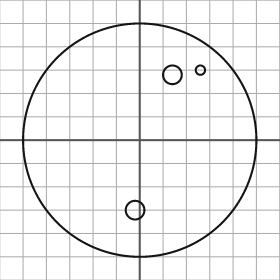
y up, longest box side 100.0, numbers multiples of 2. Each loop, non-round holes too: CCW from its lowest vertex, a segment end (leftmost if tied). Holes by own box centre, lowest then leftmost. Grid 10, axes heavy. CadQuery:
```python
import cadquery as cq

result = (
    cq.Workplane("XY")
    .moveTo(0.0, 0.0)
    .circle(50.0)
    .moveTo(-2.0, -30.0)
    .circle(4.0)
    .moveTo(14.0, 28.0)
    .circle(4.0)
    .moveTo(26.0, 30.0)
    .circle(2.0)
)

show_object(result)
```